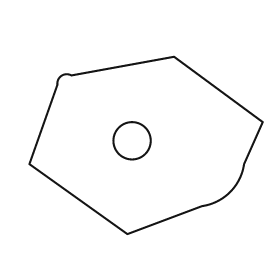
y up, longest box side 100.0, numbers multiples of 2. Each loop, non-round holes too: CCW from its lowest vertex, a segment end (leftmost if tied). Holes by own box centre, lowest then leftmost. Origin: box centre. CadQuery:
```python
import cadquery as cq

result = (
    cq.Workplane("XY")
    .moveTo(-8.0, -38.0)
    .lineTo(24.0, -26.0)
    .threePointArc((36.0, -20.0), (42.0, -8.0))
    .lineTo(50.0, 10.0)
    .lineTo(12.0, 38.0)
    .lineTo(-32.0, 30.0)
    .threePointArc((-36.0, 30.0), (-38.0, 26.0))
    .lineTo(-50.0, -8.0)
    .close()
    .moveTo(-6.0, 2.0)
    .circle(8.0)
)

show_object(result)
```